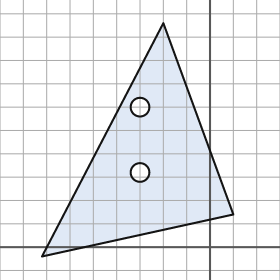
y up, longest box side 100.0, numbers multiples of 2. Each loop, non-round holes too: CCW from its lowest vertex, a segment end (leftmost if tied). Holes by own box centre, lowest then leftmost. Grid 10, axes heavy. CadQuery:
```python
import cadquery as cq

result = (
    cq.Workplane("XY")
    .moveTo(-72.0, -4.0)
    .lineTo(10.0, 14.0)
    .lineTo(-20.0, 96.0)
    .close()
    .moveTo(-30.0, 32.0)
    .circle(4.0)
    .moveTo(-30.0, 60.0)
    .circle(4.0)
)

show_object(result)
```